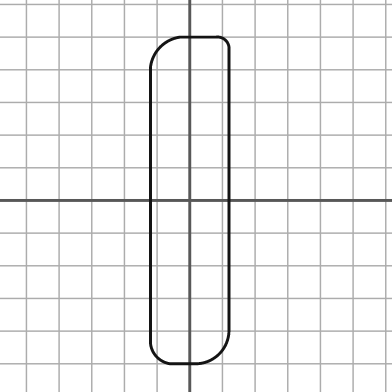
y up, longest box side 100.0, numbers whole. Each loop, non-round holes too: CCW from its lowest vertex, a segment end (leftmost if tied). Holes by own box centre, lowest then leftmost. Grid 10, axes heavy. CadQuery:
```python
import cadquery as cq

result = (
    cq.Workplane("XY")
    .moveTo(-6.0, -50.0)
    .lineTo(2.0, -50.0)
    .threePointArc((9.0, -47.0), (12.0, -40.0))
    .lineTo(12.0, 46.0)
    .threePointArc((11.0, 49.0), (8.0, 50.0))
    .lineTo(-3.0, 50.0)
    .threePointArc((-9.0, 47.0), (-12.0, 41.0))
    .lineTo(-12.0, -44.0)
    .threePointArc((-10.0, -48.0), (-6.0, -50.0))
    .close()
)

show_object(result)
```